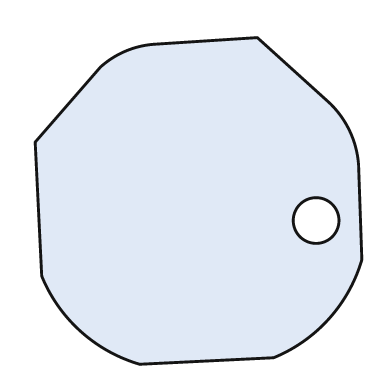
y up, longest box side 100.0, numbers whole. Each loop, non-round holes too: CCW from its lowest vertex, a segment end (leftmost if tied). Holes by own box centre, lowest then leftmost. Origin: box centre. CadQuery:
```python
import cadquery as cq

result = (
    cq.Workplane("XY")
    .moveTo(-18.0, -50.0)
    .lineTo(23.0, -48.0)
    .threePointArc((40.0, -36.0), (50.0, -18.0))
    .lineTo(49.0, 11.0)
    .threePointArc((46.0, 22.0), (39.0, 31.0))
    .lineTo(18.0, 50.0)
    .lineTo(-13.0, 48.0)
    .threePointArc((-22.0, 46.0), (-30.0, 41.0))
    .lineTo(-50.0, 18.0)
    .lineTo(-48.0, -23.0)
    .threePointArc((-36.0, -40.0), (-18.0, -50.0))
    .close()
    .moveTo(36.0, -6.0)
    .circle(7.0)
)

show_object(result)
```